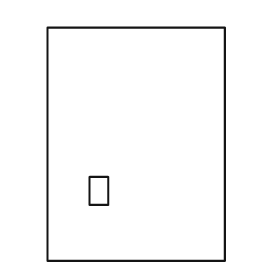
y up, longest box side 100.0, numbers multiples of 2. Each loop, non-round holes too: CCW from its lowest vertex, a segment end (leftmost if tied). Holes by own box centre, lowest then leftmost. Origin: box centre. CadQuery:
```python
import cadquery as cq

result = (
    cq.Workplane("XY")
    .moveTo(-38.0, -50.0)
    .lineTo(38.0, -50.0)
    .lineTo(38.0, 50.0)
    .lineTo(-38.0, 50.0)
    .close()
    .moveTo(-20.0, -26.0)
    .lineTo(-12.0, -26.0)
    .lineTo(-12.0, -14.0)
    .lineTo(-20.0, -14.0)
    .close()
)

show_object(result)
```